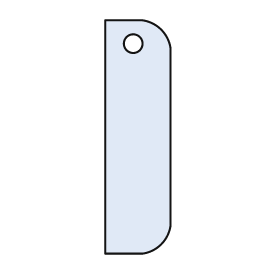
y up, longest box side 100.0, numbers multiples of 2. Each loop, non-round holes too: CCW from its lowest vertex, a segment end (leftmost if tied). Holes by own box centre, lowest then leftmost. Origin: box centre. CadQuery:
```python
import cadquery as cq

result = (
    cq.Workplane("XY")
    .moveTo(-14.0, -50.0)
    .lineTo(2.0, -50.0)
    .threePointArc((10.0, -46.0), (14.0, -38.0))
    .lineTo(14.0, 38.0)
    .threePointArc((10.0, 46.0), (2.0, 50.0))
    .lineTo(-14.0, 50.0)
    .close()
    .moveTo(-2.0, 40.0)
    .circle(4.0)
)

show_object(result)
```